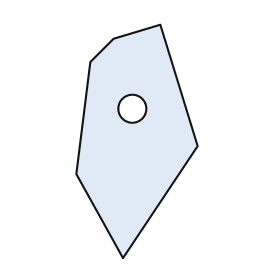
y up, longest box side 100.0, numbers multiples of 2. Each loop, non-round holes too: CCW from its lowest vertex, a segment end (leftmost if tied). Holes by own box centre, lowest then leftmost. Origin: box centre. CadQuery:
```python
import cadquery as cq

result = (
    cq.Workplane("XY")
    .moveTo(-6.0, -50.0)
    .lineTo(26.0, -2.0)
    .lineTo(10.0, 50.0)
    .lineTo(-10.0, 44.0)
    .lineTo(-20.0, 34.0)
    .lineTo(-26.0, -14.0)
    .close()
    .moveTo(-2.0, 14.0)
    .circle(6.0)
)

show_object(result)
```